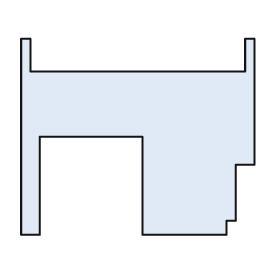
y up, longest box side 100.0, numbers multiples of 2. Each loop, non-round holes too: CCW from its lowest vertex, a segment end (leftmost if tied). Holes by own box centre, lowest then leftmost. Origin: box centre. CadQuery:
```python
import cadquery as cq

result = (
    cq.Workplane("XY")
    .moveTo(-50.0, -42.0)
    .lineTo(-42.0, -42.0)
    .lineTo(-42.0, 0.0)
    .lineTo(2.0, 0.0)
    .lineTo(2.0, -42.0)
    .lineTo(38.0, -42.0)
    .lineTo(38.0, -36.0)
    .lineTo(42.0, -36.0)
    .lineTo(42.0, -12.0)
    .lineTo(50.0, -12.0)
    .lineTo(50.0, 42.0)
    .lineTo(46.0, 42.0)
    .lineTo(46.0, 28.0)
    .lineTo(-46.0, 28.0)
    .lineTo(-46.0, 42.0)
    .lineTo(-50.0, 42.0)
    .close()
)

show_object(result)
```